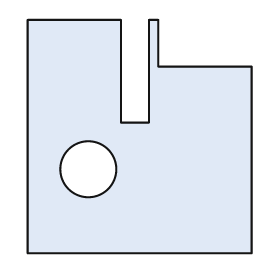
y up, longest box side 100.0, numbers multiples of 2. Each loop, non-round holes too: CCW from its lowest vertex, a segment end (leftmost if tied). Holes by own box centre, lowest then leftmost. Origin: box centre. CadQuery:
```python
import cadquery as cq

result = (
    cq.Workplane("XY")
    .moveTo(-48.0, -50.0)
    .lineTo(48.0, -50.0)
    .lineTo(48.0, 30.0)
    .lineTo(8.0, 30.0)
    .lineTo(8.0, 50.0)
    .lineTo(4.0, 50.0)
    .lineTo(4.0, 6.0)
    .lineTo(-8.0, 6.0)
    .lineTo(-8.0, 50.0)
    .lineTo(-48.0, 50.0)
    .close()
    .moveTo(-22.0, -14.0)
    .circle(12.0)
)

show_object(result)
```